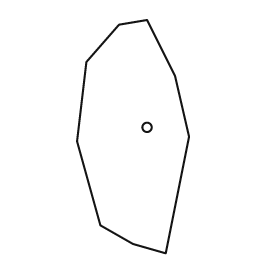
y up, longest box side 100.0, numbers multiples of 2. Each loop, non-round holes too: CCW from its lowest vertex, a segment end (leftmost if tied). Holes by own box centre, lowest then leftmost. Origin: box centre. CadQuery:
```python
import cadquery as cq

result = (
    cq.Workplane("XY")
    .moveTo(14.0, -50.0)
    .lineTo(24.0, 0.0)
    .lineTo(18.0, 26.0)
    .lineTo(6.0, 50.0)
    .lineTo(-6.0, 48.0)
    .lineTo(-20.0, 32.0)
    .lineTo(-24.0, -2.0)
    .lineTo(-14.0, -38.0)
    .lineTo(0.0, -46.0)
    .close()
    .moveTo(6.0, 4.0)
    .circle(2.0)
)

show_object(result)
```